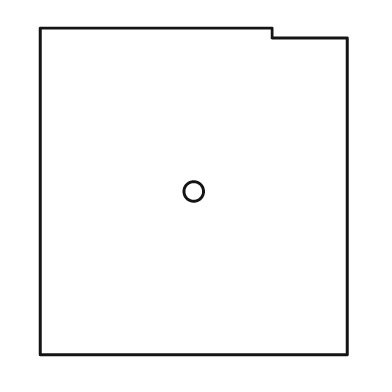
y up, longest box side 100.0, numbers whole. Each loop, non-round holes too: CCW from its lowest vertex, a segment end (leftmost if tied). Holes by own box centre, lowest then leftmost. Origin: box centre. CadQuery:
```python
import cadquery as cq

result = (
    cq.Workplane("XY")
    .moveTo(-47.0, -50.0)
    .lineTo(47.0, -50.0)
    .lineTo(47.0, 47.0)
    .lineTo(24.0, 47.0)
    .lineTo(24.0, 50.0)
    .lineTo(-47.0, 50.0)
    .close()
    .moveTo(0.0, 0.0)
    .circle(3.0)
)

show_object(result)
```